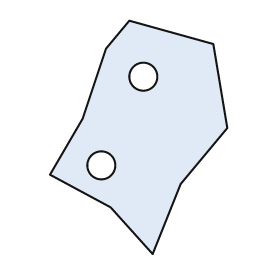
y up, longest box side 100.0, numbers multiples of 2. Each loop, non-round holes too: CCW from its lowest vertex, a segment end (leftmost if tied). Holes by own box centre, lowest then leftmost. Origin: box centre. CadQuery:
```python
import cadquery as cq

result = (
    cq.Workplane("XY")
    .moveTo(6.0, -50.0)
    .lineTo(18.0, -20.0)
    .lineTo(38.0, 4.0)
    .lineTo(32.0, 40.0)
    .lineTo(-4.0, 50.0)
    .lineTo(-14.0, 38.0)
    .lineTo(-24.0, 8.0)
    .lineTo(-38.0, -16.0)
    .lineTo(-12.0, -30.0)
    .close()
    .moveTo(-16.0, -12.0)
    .circle(6.0)
    .moveTo(2.0, 26.0)
    .circle(6.0)
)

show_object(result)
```